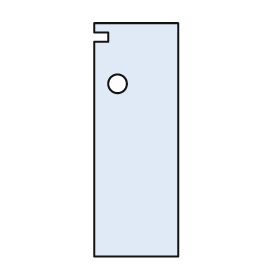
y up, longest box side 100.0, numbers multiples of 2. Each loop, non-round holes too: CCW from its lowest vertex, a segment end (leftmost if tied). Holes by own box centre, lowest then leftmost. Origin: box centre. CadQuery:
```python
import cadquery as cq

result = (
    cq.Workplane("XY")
    .moveTo(-18.0, -50.0)
    .lineTo(18.0, -50.0)
    .lineTo(18.0, 50.0)
    .lineTo(-18.0, 50.0)
    .lineTo(-18.0, 46.0)
    .lineTo(-12.0, 46.0)
    .lineTo(-12.0, 42.0)
    .lineTo(-18.0, 42.0)
    .close()
    .moveTo(-8.0, 24.0)
    .circle(4.0)
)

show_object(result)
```